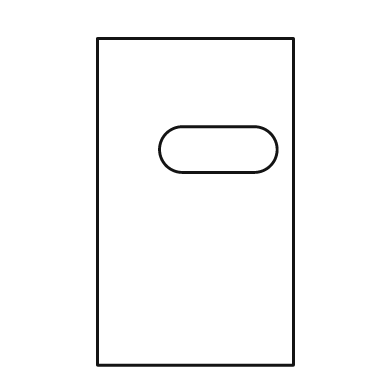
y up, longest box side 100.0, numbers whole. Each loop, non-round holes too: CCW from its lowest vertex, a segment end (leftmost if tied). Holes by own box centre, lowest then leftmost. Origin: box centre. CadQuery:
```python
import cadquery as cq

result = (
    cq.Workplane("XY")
    .moveTo(-30.0, -50.0)
    .lineTo(30.0, -50.0)
    .lineTo(30.0, 50.0)
    .lineTo(-30.0, 50.0)
    .close()
    .moveTo(-4.0, 9.0)
    .lineTo(18.0, 9.0)
    .threePointArc((25.0, 16.0), (18.0, 23.0))
    .lineTo(-4.0, 23.0)
    .threePointArc((-11.0, 16.0), (-4.0, 9.0))
    .close()
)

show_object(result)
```